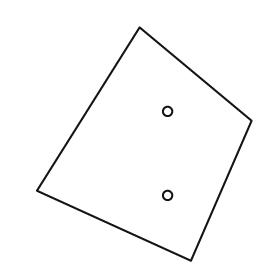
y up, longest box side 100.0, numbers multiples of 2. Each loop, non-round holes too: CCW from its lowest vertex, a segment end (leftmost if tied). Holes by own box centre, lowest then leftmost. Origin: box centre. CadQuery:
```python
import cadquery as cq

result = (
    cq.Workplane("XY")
    .moveTo(20.0, -50.0)
    .lineTo(46.0, 10.0)
    .lineTo(-2.0, 50.0)
    .lineTo(-46.0, -20.0)
    .close()
    .moveTo(10.0, -22.0)
    .circle(2.0)
    .moveTo(10.0, 14.0)
    .circle(2.0)
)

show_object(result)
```